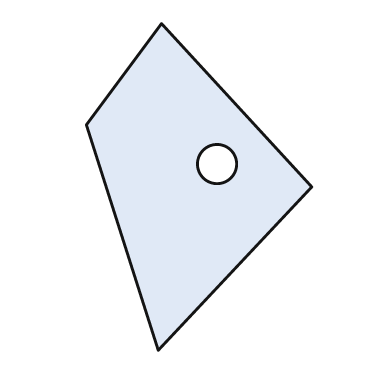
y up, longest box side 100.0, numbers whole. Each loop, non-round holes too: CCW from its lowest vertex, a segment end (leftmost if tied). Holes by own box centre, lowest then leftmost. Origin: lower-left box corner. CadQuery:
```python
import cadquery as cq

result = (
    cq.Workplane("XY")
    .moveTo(22.0, 0.0)
    .lineTo(69.0, 50.0)
    .lineTo(23.0, 100.0)
    .lineTo(0.0, 69.0)
    .close()
    .moveTo(40.0, 57.0)
    .circle(6.0)
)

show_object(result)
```